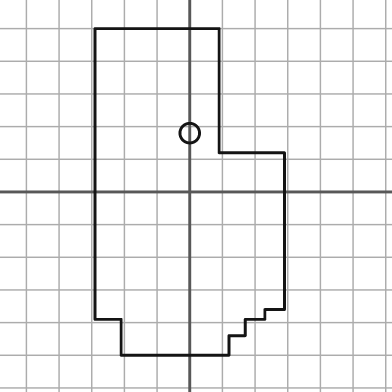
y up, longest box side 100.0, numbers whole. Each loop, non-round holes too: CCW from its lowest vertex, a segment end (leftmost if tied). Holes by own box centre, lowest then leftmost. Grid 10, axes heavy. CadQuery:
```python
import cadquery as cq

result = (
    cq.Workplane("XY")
    .moveTo(-21.0, -50.0)
    .lineTo(12.0, -50.0)
    .lineTo(12.0, -44.0)
    .lineTo(17.0, -44.0)
    .lineTo(17.0, -39.0)
    .lineTo(23.0, -39.0)
    .lineTo(23.0, -36.0)
    .lineTo(29.0, -36.0)
    .lineTo(29.0, 12.0)
    .lineTo(9.0, 12.0)
    .lineTo(9.0, 50.0)
    .lineTo(-29.0, 50.0)
    .lineTo(-29.0, -39.0)
    .lineTo(-21.0, -39.0)
    .close()
    .moveTo(0.0, 18.0)
    .circle(3.0)
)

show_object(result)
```